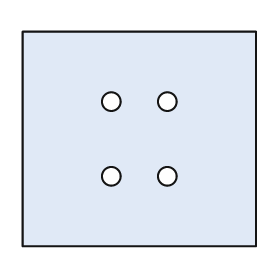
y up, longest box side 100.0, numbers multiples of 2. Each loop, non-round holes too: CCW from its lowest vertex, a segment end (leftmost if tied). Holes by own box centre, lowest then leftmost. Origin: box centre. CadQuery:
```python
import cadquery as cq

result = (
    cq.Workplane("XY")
    .moveTo(-50.0, -46.0)
    .lineTo(50.0, -46.0)
    .lineTo(50.0, 46.0)
    .lineTo(-50.0, 46.0)
    .close()
    .moveTo(-12.0, -16.0)
    .circle(4.0)
    .moveTo(12.0, -16.0)
    .circle(4.0)
    .moveTo(-12.0, 16.0)
    .circle(4.0)
    .moveTo(12.0, 16.0)
    .circle(4.0)
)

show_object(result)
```